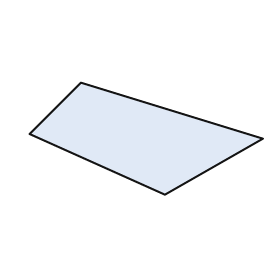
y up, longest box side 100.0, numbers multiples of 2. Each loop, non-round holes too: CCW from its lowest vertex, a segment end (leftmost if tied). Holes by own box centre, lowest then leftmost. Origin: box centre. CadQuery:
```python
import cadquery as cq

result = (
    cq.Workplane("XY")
    .moveTo(8.0, -24.0)
    .lineTo(50.0, 0.0)
    .lineTo(-28.0, 24.0)
    .lineTo(-50.0, 2.0)
    .close()
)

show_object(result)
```